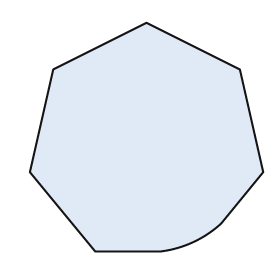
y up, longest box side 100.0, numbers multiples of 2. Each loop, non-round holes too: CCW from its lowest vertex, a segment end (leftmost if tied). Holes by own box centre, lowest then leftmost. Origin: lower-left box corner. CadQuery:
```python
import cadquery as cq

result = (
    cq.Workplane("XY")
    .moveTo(28.0, 0.0)
    .lineTo(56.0, 0.0)
    .threePointArc((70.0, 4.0), (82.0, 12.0))
    .lineTo(100.0, 34.0)
    .lineTo(90.0, 78.0)
    .lineTo(50.0, 98.0)
    .lineTo(10.0, 78.0)
    .lineTo(0.0, 34.0)
    .close()
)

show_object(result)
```